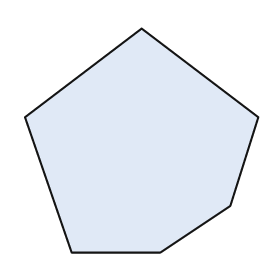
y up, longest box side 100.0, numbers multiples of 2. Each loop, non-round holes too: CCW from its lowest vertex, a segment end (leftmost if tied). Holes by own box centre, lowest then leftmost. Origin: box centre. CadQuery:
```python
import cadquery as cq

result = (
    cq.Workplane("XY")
    .moveTo(-30.0, -48.0)
    .lineTo(8.0, -48.0)
    .lineTo(38.0, -28.0)
    .lineTo(50.0, 10.0)
    .lineTo(0.0, 48.0)
    .lineTo(-50.0, 10.0)
    .close()
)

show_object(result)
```